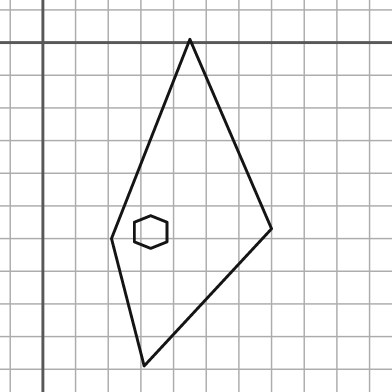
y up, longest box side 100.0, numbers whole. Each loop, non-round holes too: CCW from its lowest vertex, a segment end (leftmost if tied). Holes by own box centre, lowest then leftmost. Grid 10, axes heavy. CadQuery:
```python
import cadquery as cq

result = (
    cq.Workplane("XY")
    .moveTo(31.0, -99.0)
    .lineTo(70.0, -57.0)
    .lineTo(45.0, 1.0)
    .lineTo(21.0, -60.0)
    .close()
    .moveTo(33.0, -63.0)
    .lineTo(38.0, -61.0)
    .lineTo(38.0, -55.0)
    .lineTo(33.0, -53.0)
    .lineTo(28.0, -55.0)
    .lineTo(28.0, -61.0)
    .close()
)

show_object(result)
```